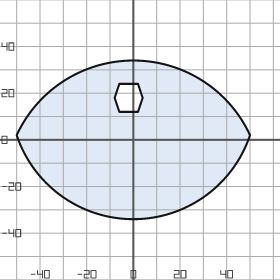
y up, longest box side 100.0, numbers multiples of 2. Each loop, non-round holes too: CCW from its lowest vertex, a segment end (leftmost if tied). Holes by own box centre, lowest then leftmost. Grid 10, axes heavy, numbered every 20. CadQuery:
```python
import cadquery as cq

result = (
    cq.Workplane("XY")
    .moveTo(-50.0, 2.0)
    .threePointArc((0.0, -34.0), (50.0, 2.0))
    .threePointArc((0.0, 34.0), (-50.0, 2.0))
    .close()
    .moveTo(-6.0, 12.0)
    .lineTo(2.0, 12.0)
    .lineTo(4.0, 18.0)
    .lineTo(2.0, 24.0)
    .lineTo(-6.0, 24.0)
    .lineTo(-8.0, 18.0)
    .close()
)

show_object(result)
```